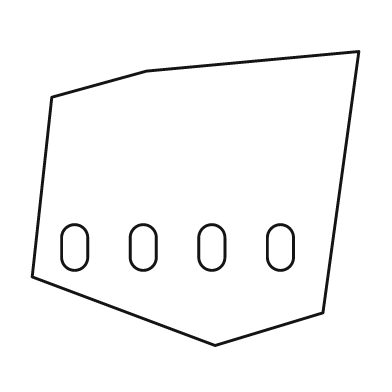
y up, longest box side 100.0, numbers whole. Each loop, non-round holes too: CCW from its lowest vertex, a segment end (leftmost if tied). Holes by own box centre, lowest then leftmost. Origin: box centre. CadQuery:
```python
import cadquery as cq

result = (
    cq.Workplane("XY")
    .moveTo(6.0, -45.0)
    .lineTo(39.0, -35.0)
    .lineTo(50.0, 45.0)
    .lineTo(-15.0, 39.0)
    .lineTo(-44.0, 31.0)
    .lineTo(-50.0, -24.0)
    .close()
    .moveTo(-41.0, -18.0)
    .threePointArc((-37.0, -22.0), (-33.0, -18.0))
    .lineTo(-33.0, -12.0)
    .threePointArc((-37.0, -8.0), (-41.0, -12.0))
    .close()
    .moveTo(-20.0, -18.0)
    .threePointArc((-16.0, -22.0), (-12.0, -18.0))
    .lineTo(-12.0, -12.0)
    .threePointArc((-16.0, -8.0), (-20.0, -12.0))
    .close()
    .moveTo(1.0, -18.0)
    .threePointArc((5.0, -22.0), (9.0, -18.0))
    .lineTo(9.0, -12.0)
    .threePointArc((5.0, -8.0), (1.0, -12.0))
    .close()
    .moveTo(22.0, -18.0)
    .threePointArc((26.0, -22.0), (30.0, -18.0))
    .lineTo(30.0, -12.0)
    .threePointArc((26.0, -8.0), (22.0, -12.0))
    .close()
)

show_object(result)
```